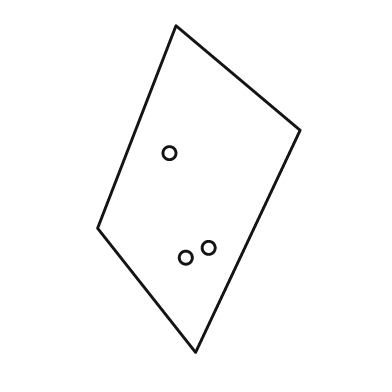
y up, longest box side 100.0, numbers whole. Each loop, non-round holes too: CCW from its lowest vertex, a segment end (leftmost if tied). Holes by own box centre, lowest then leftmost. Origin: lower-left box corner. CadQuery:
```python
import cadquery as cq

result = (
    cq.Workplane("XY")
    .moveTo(30.0, 0.0)
    .lineTo(62.0, 68.0)
    .lineTo(24.0, 100.0)
    .lineTo(0.0, 38.0)
    .close()
    .moveTo(27.0, 29.0)
    .circle(2.0)
    .moveTo(34.0, 32.0)
    .circle(2.0)
    .moveTo(22.0, 61.0)
    .circle(2.0)
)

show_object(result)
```